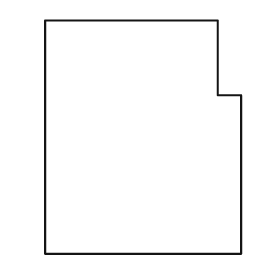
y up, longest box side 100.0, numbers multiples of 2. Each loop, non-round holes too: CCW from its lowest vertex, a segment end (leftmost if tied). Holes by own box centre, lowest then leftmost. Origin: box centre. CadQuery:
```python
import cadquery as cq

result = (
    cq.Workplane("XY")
    .moveTo(-42.0, -50.0)
    .lineTo(42.0, -50.0)
    .lineTo(42.0, 18.0)
    .lineTo(32.0, 18.0)
    .lineTo(32.0, 50.0)
    .lineTo(-42.0, 50.0)
    .close()
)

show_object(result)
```